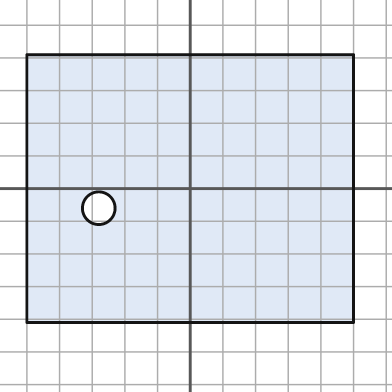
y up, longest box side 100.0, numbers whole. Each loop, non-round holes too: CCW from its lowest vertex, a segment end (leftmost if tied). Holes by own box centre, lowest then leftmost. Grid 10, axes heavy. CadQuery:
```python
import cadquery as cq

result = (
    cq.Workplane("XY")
    .moveTo(-50.0, -41.0)
    .lineTo(50.0, -41.0)
    .lineTo(50.0, 41.0)
    .lineTo(-50.0, 41.0)
    .close()
    .moveTo(-28.0, -6.0)
    .circle(5.0)
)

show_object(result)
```